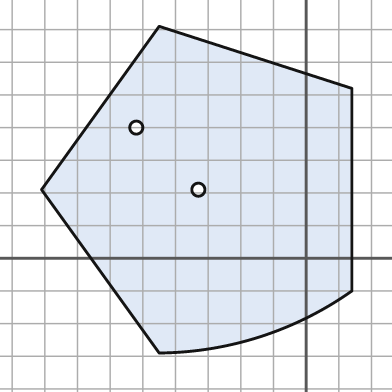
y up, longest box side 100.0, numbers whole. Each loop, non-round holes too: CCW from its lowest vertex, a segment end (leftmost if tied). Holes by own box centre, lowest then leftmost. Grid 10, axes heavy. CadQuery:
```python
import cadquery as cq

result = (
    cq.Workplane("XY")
    .moveTo(-45.0, -29.0)
    .threePointArc((-14.0, -24.0), (14.0, -10.0))
    .lineTo(14.0, 52.0)
    .lineTo(-45.0, 71.0)
    .lineTo(-81.0, 21.0)
    .close()
    .moveTo(-33.0, 21.0)
    .circle(2.0)
    .moveTo(-52.0, 40.0)
    .circle(2.0)
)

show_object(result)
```